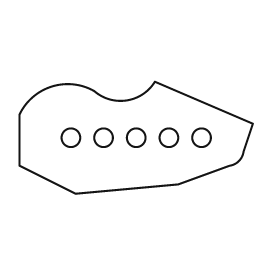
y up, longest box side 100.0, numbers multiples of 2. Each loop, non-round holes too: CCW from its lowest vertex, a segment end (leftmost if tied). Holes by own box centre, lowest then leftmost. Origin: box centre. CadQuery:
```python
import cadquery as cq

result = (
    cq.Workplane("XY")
    .moveTo(-26.0, -24.0)
    .lineTo(18.0, -20.0)
    .lineTo(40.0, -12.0)
    .threePointArc((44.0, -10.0), (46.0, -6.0))
    .lineTo(50.0, 6.0)
    .lineTo(8.0, 24.0)
    .threePointArc((-4.0, 16.0), (-18.0, 20.0))
    .threePointArc((-36.0, 22.0), (-50.0, 10.0))
    .lineTo(-50.0, -12.0)
    .close()
    .moveTo(-28.0, 0.0)
    .circle(4.0)
    .moveTo(-14.0, 0.0)
    .circle(4.0)
    .moveTo(0.0, 0.0)
    .circle(4.0)
    .moveTo(14.0, 0.0)
    .circle(4.0)
    .moveTo(28.0, 0.0)
    .circle(4.0)
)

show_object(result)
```